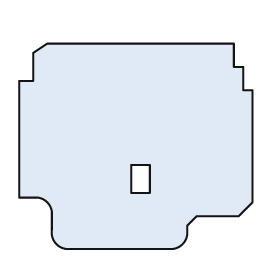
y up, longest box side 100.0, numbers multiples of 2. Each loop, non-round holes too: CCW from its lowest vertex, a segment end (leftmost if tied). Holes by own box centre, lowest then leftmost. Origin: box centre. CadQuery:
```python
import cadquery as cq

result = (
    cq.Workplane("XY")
    .moveTo(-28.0, -44.0)
    .lineTo(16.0, -44.0)
    .threePointArc((20.0, -42.0), (22.0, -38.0))
    .lineTo(22.0, -34.0)
    .lineTo(26.0, -30.0)
    .lineTo(44.0, -30.0)
    .lineTo(50.0, -24.0)
    .lineTo(50.0, 24.0)
    .lineTo(46.0, 24.0)
    .lineTo(46.0, 34.0)
    .lineTo(42.0, 34.0)
    .lineTo(42.0, 44.0)
    .lineTo(-38.0, 44.0)
    .lineTo(-44.0, 40.0)
    .lineTo(-44.0, 28.0)
    .lineTo(-50.0, 28.0)
    .lineTo(-50.0, -22.0)
    .lineTo(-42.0, -22.0)
    .threePointArc((-38.0, -24.0), (-36.0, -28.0))
    .lineTo(-36.0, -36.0)
    .threePointArc((-34.0, -42.0), (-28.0, -44.0))
    .close()
    .moveTo(-2.0, -20.0)
    .lineTo(6.0, -20.0)
    .lineTo(6.0, -8.0)
    .lineTo(-2.0, -8.0)
    .close()
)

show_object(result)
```